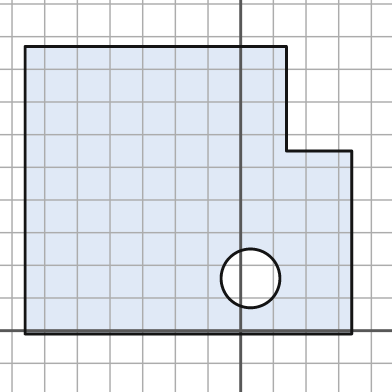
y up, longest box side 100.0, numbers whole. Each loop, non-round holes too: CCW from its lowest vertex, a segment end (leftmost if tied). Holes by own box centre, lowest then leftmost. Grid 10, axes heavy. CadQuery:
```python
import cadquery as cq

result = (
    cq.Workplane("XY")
    .moveTo(-66.0, -1.0)
    .lineTo(34.0, -1.0)
    .lineTo(34.0, 55.0)
    .lineTo(14.0, 55.0)
    .lineTo(14.0, 87.0)
    .lineTo(-66.0, 87.0)
    .close()
    .moveTo(3.0, 16.0)
    .circle(9.0)
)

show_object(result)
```